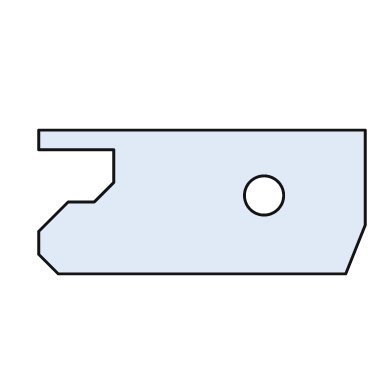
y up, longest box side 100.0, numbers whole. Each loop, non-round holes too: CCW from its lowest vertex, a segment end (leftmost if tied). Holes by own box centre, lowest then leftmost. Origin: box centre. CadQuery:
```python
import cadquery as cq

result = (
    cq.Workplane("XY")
    .moveTo(-44.0, -22.0)
    .lineTo(44.0, -22.0)
    .lineTo(50.0, -7.0)
    .lineTo(50.0, 22.0)
    .lineTo(-50.0, 22.0)
    .lineTo(-50.0, 16.0)
    .lineTo(-27.0, 16.0)
    .lineTo(-27.0, 6.0)
    .lineTo(-33.0, 0.0)
    .lineTo(-41.0, 0.0)
    .lineTo(-50.0, -9.0)
    .lineTo(-50.0, -16.0)
    .close()
    .moveTo(19.0, 2.0)
    .circle(6.0)
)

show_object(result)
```